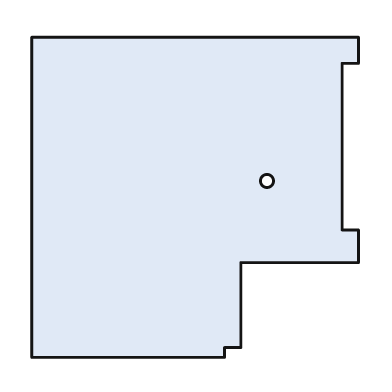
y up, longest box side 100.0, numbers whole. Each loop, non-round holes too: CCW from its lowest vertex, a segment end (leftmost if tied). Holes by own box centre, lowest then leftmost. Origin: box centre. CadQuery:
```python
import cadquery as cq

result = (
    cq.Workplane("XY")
    .moveTo(-50.0, -49.0)
    .lineTo(9.0, -49.0)
    .lineTo(9.0, -46.0)
    .lineTo(14.0, -46.0)
    .lineTo(14.0, -20.0)
    .lineTo(50.0, -20.0)
    .lineTo(50.0, -10.0)
    .lineTo(45.0, -10.0)
    .lineTo(45.0, 41.0)
    .lineTo(50.0, 41.0)
    .lineTo(50.0, 49.0)
    .lineTo(-50.0, 49.0)
    .close()
    .moveTo(22.0, 5.0)
    .circle(2.0)
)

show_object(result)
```